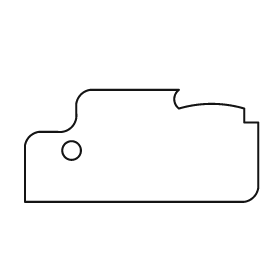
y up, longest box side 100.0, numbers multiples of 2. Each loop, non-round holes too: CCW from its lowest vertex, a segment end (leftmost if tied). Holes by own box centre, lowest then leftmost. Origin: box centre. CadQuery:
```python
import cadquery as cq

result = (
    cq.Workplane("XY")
    .moveTo(-50.0, -24.0)
    .lineTo(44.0, -24.0)
    .threePointArc((48.0, -22.0), (50.0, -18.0))
    .lineTo(50.0, 10.0)
    .lineTo(44.0, 10.0)
    .lineTo(44.0, 16.0)
    .threePointArc((30.0, 18.0), (16.0, 16.0))
    .threePointArc((14.0, 20.0), (16.0, 24.0))
    .lineTo(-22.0, 24.0)
    .threePointArc((-26.0, 22.0), (-28.0, 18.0))
    .lineTo(-28.0, 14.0)
    .threePointArc((-30.0, 8.0), (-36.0, 6.0))
    .lineTo(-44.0, 6.0)
    .threePointArc((-48.0, 4.0), (-50.0, 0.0))
    .close()
    .moveTo(-30.0, -2.0)
    .circle(4.0)
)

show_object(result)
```